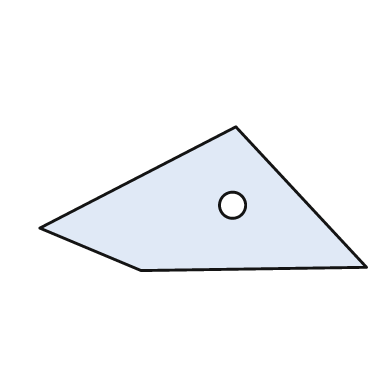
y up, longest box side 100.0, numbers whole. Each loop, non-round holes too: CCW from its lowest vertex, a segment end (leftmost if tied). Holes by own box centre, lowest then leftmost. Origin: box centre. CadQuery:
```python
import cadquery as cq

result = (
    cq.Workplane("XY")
    .moveTo(-19.0, -22.0)
    .lineTo(50.0, -21.0)
    .lineTo(10.0, 22.0)
    .lineTo(-50.0, -9.0)
    .close()
    .moveTo(9.0, -2.0)
    .circle(4.0)
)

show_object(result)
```